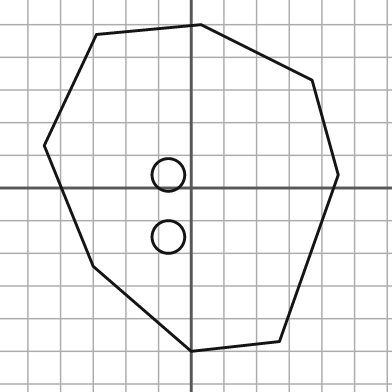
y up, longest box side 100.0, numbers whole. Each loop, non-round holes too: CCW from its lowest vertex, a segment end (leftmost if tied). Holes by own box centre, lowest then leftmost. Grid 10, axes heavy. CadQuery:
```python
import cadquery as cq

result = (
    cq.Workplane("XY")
    .moveTo(0.0, -50.0)
    .lineTo(27.0, -47.0)
    .lineTo(45.0, 4.0)
    .lineTo(37.0, 33.0)
    .lineTo(3.0, 50.0)
    .lineTo(-29.0, 47.0)
    .lineTo(-45.0, 13.0)
    .lineTo(-30.0, -24.0)
    .close()
    .moveTo(-7.0, -15.0)
    .circle(5.0)
    .moveTo(-7.0, 4.0)
    .circle(5.0)
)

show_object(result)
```